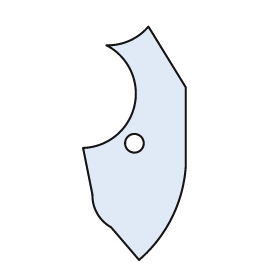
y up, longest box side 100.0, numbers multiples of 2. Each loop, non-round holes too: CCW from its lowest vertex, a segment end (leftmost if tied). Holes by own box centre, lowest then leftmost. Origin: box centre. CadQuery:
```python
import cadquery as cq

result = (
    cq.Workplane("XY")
    .moveTo(2.0, -50.0)
    .threePointArc((16.0, -32.0), (22.0, -10.0))
    .lineTo(22.0, 24.0)
    .lineTo(6.0, 50.0)
    .threePointArc((-2.0, 44.0), (-12.0, 42.0))
    .threePointArc((0.0, 16.0), (-22.0, -2.0))
    .lineTo(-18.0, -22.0)
    .threePointArc((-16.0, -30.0), (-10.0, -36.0))
    .close()
    .moveTo(0.0, 0.0)
    .circle(4.0)
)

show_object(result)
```